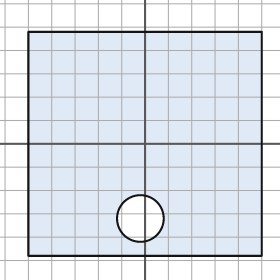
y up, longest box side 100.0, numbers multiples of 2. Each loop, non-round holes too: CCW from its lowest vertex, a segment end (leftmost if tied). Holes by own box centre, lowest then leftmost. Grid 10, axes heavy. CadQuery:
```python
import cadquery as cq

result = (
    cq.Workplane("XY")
    .moveTo(-50.0, -48.0)
    .lineTo(50.0, -48.0)
    .lineTo(50.0, 48.0)
    .lineTo(-50.0, 48.0)
    .close()
    .moveTo(-2.0, -32.0)
    .circle(10.0)
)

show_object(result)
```